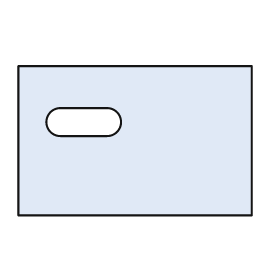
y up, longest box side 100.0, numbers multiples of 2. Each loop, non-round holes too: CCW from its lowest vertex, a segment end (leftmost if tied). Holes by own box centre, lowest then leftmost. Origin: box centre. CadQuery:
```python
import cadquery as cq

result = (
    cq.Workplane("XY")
    .moveTo(-50.0, -32.0)
    .lineTo(50.0, -32.0)
    .lineTo(50.0, 32.0)
    .lineTo(-50.0, 32.0)
    .close()
    .moveTo(-32.0, 2.0)
    .lineTo(-12.0, 2.0)
    .threePointArc((-6.0, 8.0), (-12.0, 14.0))
    .lineTo(-32.0, 14.0)
    .threePointArc((-38.0, 8.0), (-32.0, 2.0))
    .close()
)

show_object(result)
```